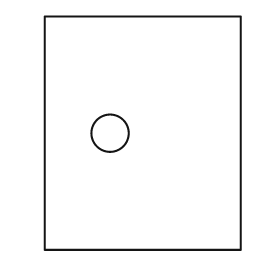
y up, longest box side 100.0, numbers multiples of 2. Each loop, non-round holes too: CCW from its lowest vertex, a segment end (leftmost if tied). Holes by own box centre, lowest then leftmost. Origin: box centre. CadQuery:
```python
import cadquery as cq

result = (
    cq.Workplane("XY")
    .moveTo(-42.0, -50.0)
    .lineTo(42.0, -50.0)
    .lineTo(42.0, 50.0)
    .lineTo(-42.0, 50.0)
    .close()
    .moveTo(-14.0, 0.0)
    .circle(8.0)
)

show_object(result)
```